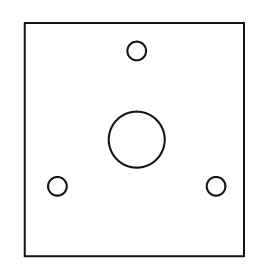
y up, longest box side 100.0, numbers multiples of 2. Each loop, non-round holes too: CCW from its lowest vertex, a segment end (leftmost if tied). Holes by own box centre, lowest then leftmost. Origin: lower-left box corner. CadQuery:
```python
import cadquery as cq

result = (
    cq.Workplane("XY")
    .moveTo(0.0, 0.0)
    .lineTo(94.0, 0.0)
    .lineTo(94.0, 100.0)
    .lineTo(0.0, 100.0)
    .close()
    .moveTo(14.0, 30.0)
    .circle(4.0)
    .moveTo(82.0, 30.0)
    .circle(4.0)
    .moveTo(48.0, 50.0)
    .circle(12.0)
    .moveTo(48.0, 88.0)
    .circle(4.0)
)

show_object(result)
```